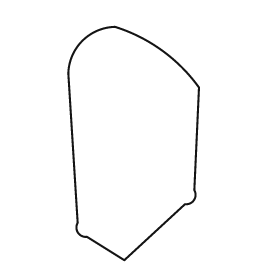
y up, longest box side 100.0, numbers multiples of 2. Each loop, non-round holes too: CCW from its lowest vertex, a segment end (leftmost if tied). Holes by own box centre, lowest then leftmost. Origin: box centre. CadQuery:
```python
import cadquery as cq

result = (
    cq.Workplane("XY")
    .moveTo(-4.0, -50.0)
    .lineTo(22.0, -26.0)
    .threePointArc((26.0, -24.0), (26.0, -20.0))
    .lineTo(28.0, 24.0)
    .threePointArc((12.0, 40.0), (-8.0, 50.0))
    .threePointArc((-22.0, 44.0), (-28.0, 30.0))
    .lineTo(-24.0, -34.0)
    .threePointArc((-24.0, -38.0), (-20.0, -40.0))
    .close()
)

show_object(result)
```